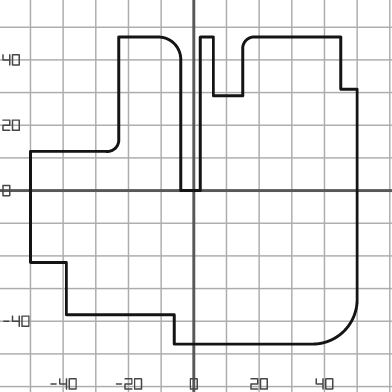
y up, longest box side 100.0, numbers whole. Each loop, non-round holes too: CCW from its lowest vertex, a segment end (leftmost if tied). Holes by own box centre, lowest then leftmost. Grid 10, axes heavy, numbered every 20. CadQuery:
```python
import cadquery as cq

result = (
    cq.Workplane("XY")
    .moveTo(-6.0, -47.0)
    .lineTo(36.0, -47.0)
    .threePointArc((46.0, -43.0), (50.0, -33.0))
    .lineTo(50.0, 31.0)
    .lineTo(45.0, 31.0)
    .lineTo(45.0, 47.0)
    .lineTo(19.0, 47.0)
    .threePointArc((16.0, 46.0), (15.0, 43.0))
    .lineTo(15.0, 29.0)
    .lineTo(6.0, 29.0)
    .lineTo(6.0, 47.0)
    .lineTo(2.0, 47.0)
    .lineTo(2.0, 0.0)
    .lineTo(-4.0, 0.0)
    .lineTo(-4.0, 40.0)
    .threePointArc((-6.0, 45.0), (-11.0, 47.0))
    .lineTo(-23.0, 47.0)
    .lineTo(-23.0, 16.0)
    .threePointArc((-24.0, 13.0), (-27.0, 12.0))
    .lineTo(-50.0, 12.0)
    .lineTo(-50.0, -22.0)
    .lineTo(-39.0, -22.0)
    .lineTo(-39.0, -38.0)
    .lineTo(-6.0, -38.0)
    .close()
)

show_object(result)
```